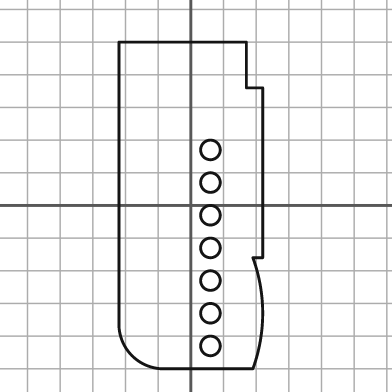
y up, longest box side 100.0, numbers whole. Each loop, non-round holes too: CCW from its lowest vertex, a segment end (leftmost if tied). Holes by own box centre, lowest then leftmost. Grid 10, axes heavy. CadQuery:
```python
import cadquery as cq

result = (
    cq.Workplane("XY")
    .moveTo(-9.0, -50.0)
    .lineTo(19.0, -50.0)
    .threePointArc((22.0, -33.0), (19.0, -16.0))
    .lineTo(22.0, -16.0)
    .lineTo(22.0, 36.0)
    .lineTo(17.0, 36.0)
    .lineTo(17.0, 50.0)
    .lineTo(-22.0, 50.0)
    .lineTo(-22.0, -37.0)
    .threePointArc((-18.0, -46.0), (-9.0, -50.0))
    .close()
    .moveTo(6.0, -43.0)
    .circle(3.0)
    .moveTo(6.0, -33.0)
    .circle(3.0)
    .moveTo(6.0, -23.0)
    .circle(3.0)
    .moveTo(6.0, -13.0)
    .circle(3.0)
    .moveTo(6.0, -3.0)
    .circle(3.0)
    .moveTo(6.0, 7.0)
    .circle(3.0)
    .moveTo(6.0, 17.0)
    .circle(3.0)
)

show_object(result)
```